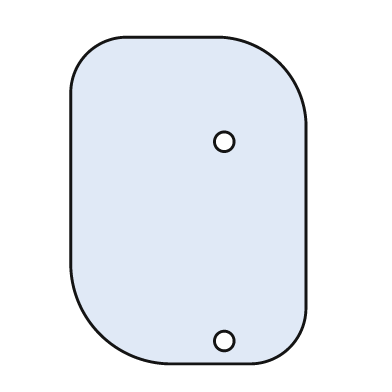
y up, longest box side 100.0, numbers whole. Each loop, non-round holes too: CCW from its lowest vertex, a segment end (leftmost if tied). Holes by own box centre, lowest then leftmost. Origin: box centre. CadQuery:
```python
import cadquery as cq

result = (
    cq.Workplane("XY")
    .moveTo(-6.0, -50.0)
    .lineTo(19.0, -50.0)
    .threePointArc((31.0, -45.0), (36.0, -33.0))
    .lineTo(36.0, 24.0)
    .threePointArc((28.0, 42.0), (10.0, 50.0))
    .lineTo(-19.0, 50.0)
    .threePointArc((-31.0, 45.0), (-36.0, 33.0))
    .lineTo(-36.0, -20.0)
    .threePointArc((-27.0, -41.0), (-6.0, -50.0))
    .close()
    .moveTo(11.0, -43.0)
    .circle(3.0)
    .moveTo(11.0, 18.0)
    .circle(3.0)
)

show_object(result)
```